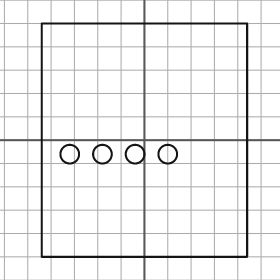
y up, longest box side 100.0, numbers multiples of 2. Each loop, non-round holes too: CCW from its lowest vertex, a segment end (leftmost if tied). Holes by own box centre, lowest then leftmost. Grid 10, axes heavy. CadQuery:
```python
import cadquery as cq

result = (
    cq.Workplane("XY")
    .moveTo(-44.0, -50.0)
    .lineTo(44.0, -50.0)
    .lineTo(44.0, 50.0)
    .lineTo(-44.0, 50.0)
    .close()
    .moveTo(-32.0, -6.0)
    .circle(4.0)
    .moveTo(-18.0, -6.0)
    .circle(4.0)
    .moveTo(-4.0, -6.0)
    .circle(4.0)
    .moveTo(10.0, -6.0)
    .circle(4.0)
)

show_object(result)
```